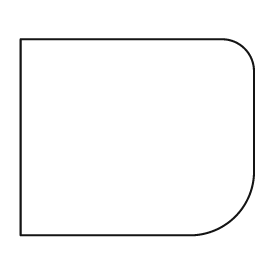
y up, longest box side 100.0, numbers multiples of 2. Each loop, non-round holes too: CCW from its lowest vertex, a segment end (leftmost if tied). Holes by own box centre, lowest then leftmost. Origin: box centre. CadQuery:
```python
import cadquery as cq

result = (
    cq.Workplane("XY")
    .moveTo(-50.0, -42.0)
    .lineTo(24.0, -42.0)
    .threePointArc((42.0, -34.0), (50.0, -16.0))
    .lineTo(50.0, 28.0)
    .threePointArc((46.0, 38.0), (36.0, 42.0))
    .lineTo(-50.0, 42.0)
    .close()
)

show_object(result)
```